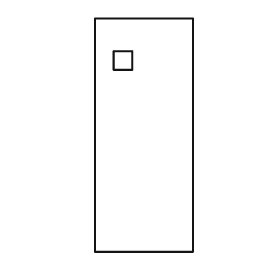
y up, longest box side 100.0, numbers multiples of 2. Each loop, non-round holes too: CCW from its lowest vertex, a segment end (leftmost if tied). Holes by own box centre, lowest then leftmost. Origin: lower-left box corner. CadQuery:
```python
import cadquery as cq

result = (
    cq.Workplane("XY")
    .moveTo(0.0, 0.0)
    .lineTo(42.0, 0.0)
    .lineTo(42.0, 100.0)
    .lineTo(0.0, 100.0)
    .close()
    .moveTo(8.0, 78.0)
    .lineTo(16.0, 78.0)
    .lineTo(16.0, 86.0)
    .lineTo(8.0, 86.0)
    .close()
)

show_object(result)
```